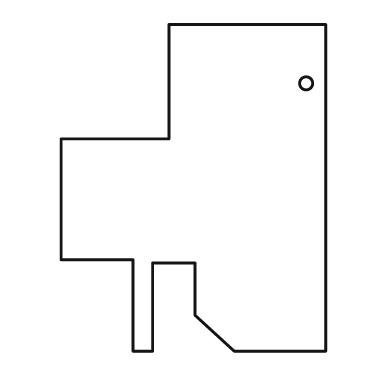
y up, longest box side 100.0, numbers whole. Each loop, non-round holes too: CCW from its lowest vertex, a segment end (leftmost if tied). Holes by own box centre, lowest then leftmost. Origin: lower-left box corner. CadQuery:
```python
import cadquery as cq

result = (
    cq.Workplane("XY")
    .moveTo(22.0, 0.0)
    .lineTo(28.0, 0.0)
    .lineTo(28.0, 27.0)
    .lineTo(41.0, 27.0)
    .lineTo(41.0, 11.0)
    .lineTo(53.0, 0.0)
    .lineTo(81.0, 0.0)
    .lineTo(81.0, 100.0)
    .lineTo(33.0, 100.0)
    .lineTo(33.0, 65.0)
    .lineTo(0.0, 65.0)
    .lineTo(0.0, 28.0)
    .lineTo(22.0, 28.0)
    .close()
    .moveTo(75.0, 82.0)
    .circle(2.0)
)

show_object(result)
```